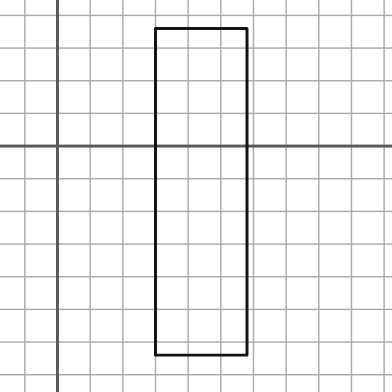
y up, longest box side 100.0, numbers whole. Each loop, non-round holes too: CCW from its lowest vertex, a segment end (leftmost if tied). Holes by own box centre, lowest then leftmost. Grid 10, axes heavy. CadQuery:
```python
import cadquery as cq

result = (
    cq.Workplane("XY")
    .moveTo(30.0, -64.0)
    .lineTo(58.0, -64.0)
    .lineTo(58.0, 36.0)
    .lineTo(30.0, 36.0)
    .close()
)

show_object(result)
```